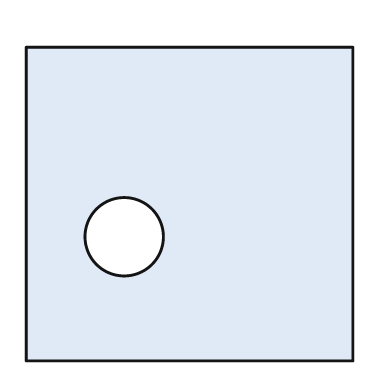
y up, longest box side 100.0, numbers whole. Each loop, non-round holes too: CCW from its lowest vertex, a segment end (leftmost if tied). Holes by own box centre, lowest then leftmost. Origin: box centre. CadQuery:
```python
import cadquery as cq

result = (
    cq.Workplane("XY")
    .moveTo(-50.0, -48.0)
    .lineTo(50.0, -48.0)
    .lineTo(50.0, 48.0)
    .lineTo(-50.0, 48.0)
    .close()
    .moveTo(-20.0, -10.0)
    .circle(12.0)
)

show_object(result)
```